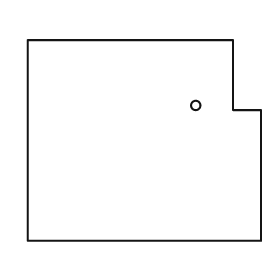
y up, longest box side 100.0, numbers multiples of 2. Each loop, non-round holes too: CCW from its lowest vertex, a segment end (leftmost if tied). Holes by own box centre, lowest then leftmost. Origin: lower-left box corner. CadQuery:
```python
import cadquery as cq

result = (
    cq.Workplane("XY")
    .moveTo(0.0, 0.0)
    .lineTo(100.0, 0.0)
    .lineTo(100.0, 56.0)
    .lineTo(88.0, 56.0)
    .lineTo(88.0, 86.0)
    .lineTo(0.0, 86.0)
    .close()
    .moveTo(72.0, 58.0)
    .circle(2.0)
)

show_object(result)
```